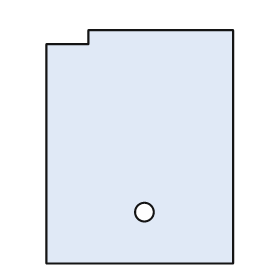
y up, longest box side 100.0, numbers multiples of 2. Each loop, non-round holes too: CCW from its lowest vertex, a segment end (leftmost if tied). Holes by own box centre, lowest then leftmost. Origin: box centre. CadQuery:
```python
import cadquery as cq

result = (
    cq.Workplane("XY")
    .moveTo(-40.0, -50.0)
    .lineTo(40.0, -50.0)
    .lineTo(40.0, 50.0)
    .lineTo(-22.0, 50.0)
    .lineTo(-22.0, 44.0)
    .lineTo(-40.0, 44.0)
    .close()
    .moveTo(2.0, -28.0)
    .circle(4.0)
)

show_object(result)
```